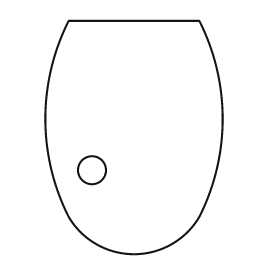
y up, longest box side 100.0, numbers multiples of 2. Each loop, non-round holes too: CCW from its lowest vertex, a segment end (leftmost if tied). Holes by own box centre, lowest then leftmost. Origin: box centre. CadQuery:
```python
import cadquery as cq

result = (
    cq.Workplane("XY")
    .moveTo(-28.0, -34.0)
    .threePointArc((0.0, -50.0), (28.0, -34.0))
    .threePointArc((38.0, 8.0), (28.0, 50.0))
    .lineTo(-28.0, 50.0)
    .threePointArc((-38.0, 8.0), (-28.0, -34.0))
    .close()
    .moveTo(-18.0, -14.0)
    .circle(6.0)
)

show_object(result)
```